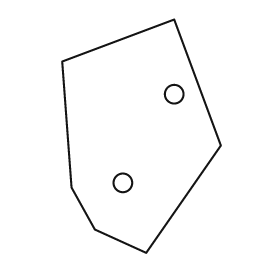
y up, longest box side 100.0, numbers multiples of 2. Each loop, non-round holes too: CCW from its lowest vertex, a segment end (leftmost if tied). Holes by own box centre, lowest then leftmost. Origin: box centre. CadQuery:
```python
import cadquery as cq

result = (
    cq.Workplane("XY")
    .moveTo(2.0, -50.0)
    .lineTo(34.0, -4.0)
    .lineTo(14.0, 50.0)
    .lineTo(-34.0, 32.0)
    .lineTo(-30.0, -22.0)
    .lineTo(-20.0, -40.0)
    .close()
    .moveTo(-8.0, -20.0)
    .circle(4.0)
    .moveTo(14.0, 18.0)
    .circle(4.0)
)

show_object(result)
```